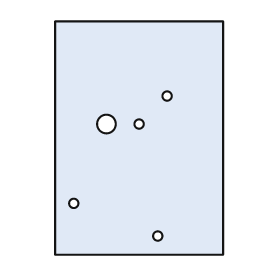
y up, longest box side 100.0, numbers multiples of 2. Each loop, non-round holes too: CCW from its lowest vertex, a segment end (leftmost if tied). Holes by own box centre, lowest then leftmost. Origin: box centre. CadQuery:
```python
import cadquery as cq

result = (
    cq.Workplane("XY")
    .moveTo(-36.0, -50.0)
    .lineTo(36.0, -50.0)
    .lineTo(36.0, 50.0)
    .lineTo(-36.0, 50.0)
    .close()
    .moveTo(8.0, -42.0)
    .circle(2.0)
    .moveTo(-28.0, -28.0)
    .circle(2.0)
    .moveTo(-14.0, 6.0)
    .circle(4.0)
    .moveTo(0.0, 6.0)
    .circle(2.0)
    .moveTo(12.0, 18.0)
    .circle(2.0)
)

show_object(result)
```